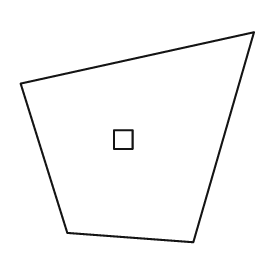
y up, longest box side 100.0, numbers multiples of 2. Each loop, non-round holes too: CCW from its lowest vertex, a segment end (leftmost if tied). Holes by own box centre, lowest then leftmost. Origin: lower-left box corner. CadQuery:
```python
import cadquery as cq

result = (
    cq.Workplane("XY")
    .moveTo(74.0, 0.0)
    .lineTo(100.0, 90.0)
    .lineTo(0.0, 68.0)
    .lineTo(20.0, 4.0)
    .close()
    .moveTo(40.0, 40.0)
    .lineTo(48.0, 40.0)
    .lineTo(48.0, 48.0)
    .lineTo(40.0, 48.0)
    .close()
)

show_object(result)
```